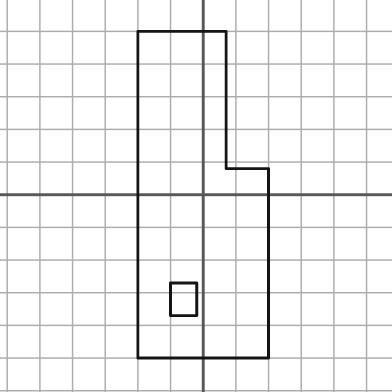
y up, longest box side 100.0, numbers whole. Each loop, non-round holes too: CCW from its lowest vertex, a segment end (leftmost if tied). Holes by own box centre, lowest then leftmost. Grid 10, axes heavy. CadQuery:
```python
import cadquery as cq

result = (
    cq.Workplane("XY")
    .moveTo(-20.0, -50.0)
    .lineTo(20.0, -50.0)
    .lineTo(20.0, 8.0)
    .lineTo(7.0, 8.0)
    .lineTo(7.0, 50.0)
    .lineTo(-20.0, 50.0)
    .close()
    .moveTo(-10.0, -37.0)
    .lineTo(-2.0, -37.0)
    .lineTo(-2.0, -27.0)
    .lineTo(-10.0, -27.0)
    .close()
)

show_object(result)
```